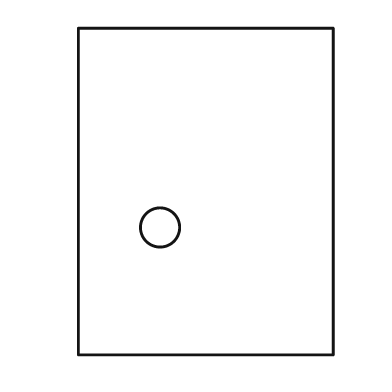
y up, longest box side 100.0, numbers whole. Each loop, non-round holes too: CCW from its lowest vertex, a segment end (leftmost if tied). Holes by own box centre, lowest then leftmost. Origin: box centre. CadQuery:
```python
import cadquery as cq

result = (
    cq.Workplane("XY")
    .moveTo(-39.0, -50.0)
    .lineTo(39.0, -50.0)
    .lineTo(39.0, 50.0)
    .lineTo(-39.0, 50.0)
    .close()
    .moveTo(-14.0, -11.0)
    .circle(6.0)
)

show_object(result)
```